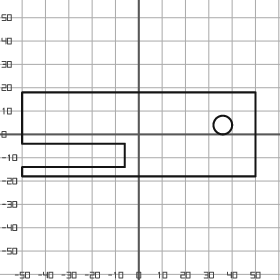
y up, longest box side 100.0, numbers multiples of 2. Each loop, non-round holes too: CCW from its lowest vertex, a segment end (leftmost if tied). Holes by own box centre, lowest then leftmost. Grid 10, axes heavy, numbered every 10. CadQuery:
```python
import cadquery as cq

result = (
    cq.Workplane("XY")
    .moveTo(-50.0, -18.0)
    .lineTo(50.0, -18.0)
    .lineTo(50.0, 18.0)
    .lineTo(-50.0, 18.0)
    .lineTo(-50.0, -4.0)
    .lineTo(-6.0, -4.0)
    .lineTo(-6.0, -14.0)
    .lineTo(-50.0, -14.0)
    .close()
    .moveTo(36.0, 4.0)
    .circle(4.0)
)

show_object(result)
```